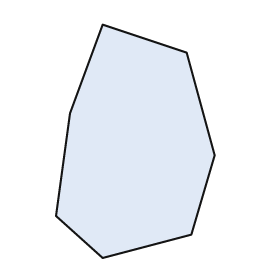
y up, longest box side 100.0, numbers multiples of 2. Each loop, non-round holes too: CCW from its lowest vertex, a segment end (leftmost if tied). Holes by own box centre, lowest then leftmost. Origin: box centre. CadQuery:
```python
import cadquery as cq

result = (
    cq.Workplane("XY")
    .moveTo(-14.0, -50.0)
    .lineTo(24.0, -40.0)
    .lineTo(34.0, -6.0)
    .lineTo(22.0, 38.0)
    .lineTo(-14.0, 50.0)
    .lineTo(-28.0, 12.0)
    .lineTo(-34.0, -32.0)
    .close()
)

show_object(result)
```